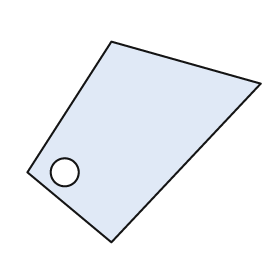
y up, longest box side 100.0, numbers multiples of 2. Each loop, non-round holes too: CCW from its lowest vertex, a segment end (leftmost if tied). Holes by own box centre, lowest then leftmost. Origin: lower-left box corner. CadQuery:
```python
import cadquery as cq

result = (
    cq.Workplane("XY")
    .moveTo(36.0, 0.0)
    .lineTo(100.0, 68.0)
    .lineTo(36.0, 86.0)
    .lineTo(0.0, 30.0)
    .close()
    .moveTo(16.0, 30.0)
    .circle(6.0)
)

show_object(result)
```